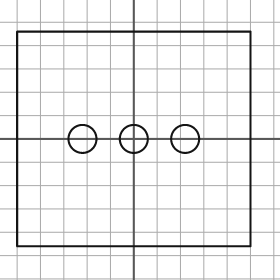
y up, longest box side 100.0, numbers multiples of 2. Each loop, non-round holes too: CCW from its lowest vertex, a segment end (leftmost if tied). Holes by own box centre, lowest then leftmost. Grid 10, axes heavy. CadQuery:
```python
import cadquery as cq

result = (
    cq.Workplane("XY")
    .moveTo(-50.0, -46.0)
    .lineTo(50.0, -46.0)
    .lineTo(50.0, 46.0)
    .lineTo(-50.0, 46.0)
    .close()
    .moveTo(-22.0, 0.0)
    .circle(6.0)
    .moveTo(0.0, 0.0)
    .circle(6.0)
    .moveTo(22.0, 0.0)
    .circle(6.0)
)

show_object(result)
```